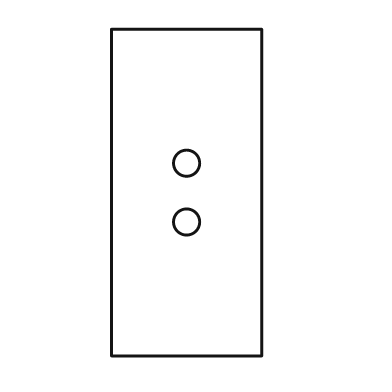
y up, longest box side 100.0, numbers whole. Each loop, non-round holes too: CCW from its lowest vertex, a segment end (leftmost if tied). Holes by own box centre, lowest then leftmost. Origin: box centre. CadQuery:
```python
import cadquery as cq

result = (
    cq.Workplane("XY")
    .moveTo(-23.0, -50.0)
    .lineTo(23.0, -50.0)
    .lineTo(23.0, 50.0)
    .lineTo(-23.0, 50.0)
    .close()
    .moveTo(0.0, -9.0)
    .circle(4.0)
    .moveTo(0.0, 9.0)
    .circle(4.0)
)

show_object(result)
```